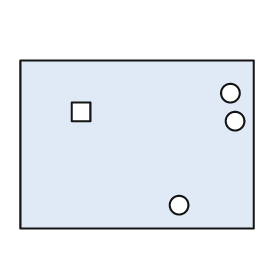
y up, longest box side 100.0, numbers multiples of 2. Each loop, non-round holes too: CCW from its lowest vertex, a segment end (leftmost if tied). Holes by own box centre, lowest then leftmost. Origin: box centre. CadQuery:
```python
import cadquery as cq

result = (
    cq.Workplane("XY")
    .moveTo(-50.0, -36.0)
    .lineTo(50.0, -36.0)
    .lineTo(50.0, 36.0)
    .lineTo(-50.0, 36.0)
    .close()
    .moveTo(18.0, -26.0)
    .circle(4.0)
    .moveTo(42.0, 10.0)
    .circle(4.0)
    .moveTo(-28.0, 10.0)
    .lineTo(-20.0, 10.0)
    .lineTo(-20.0, 18.0)
    .lineTo(-28.0, 18.0)
    .close()
    .moveTo(40.0, 22.0)
    .circle(4.0)
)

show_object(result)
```